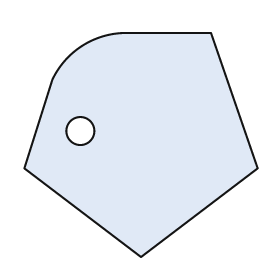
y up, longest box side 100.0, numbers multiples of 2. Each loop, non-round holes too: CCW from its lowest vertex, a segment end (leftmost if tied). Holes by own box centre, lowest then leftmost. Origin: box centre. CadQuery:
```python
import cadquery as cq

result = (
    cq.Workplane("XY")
    .moveTo(0.0, -48.0)
    .lineTo(50.0, -10.0)
    .lineTo(30.0, 48.0)
    .lineTo(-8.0, 48.0)
    .threePointArc((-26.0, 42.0), (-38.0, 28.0))
    .lineTo(-50.0, -10.0)
    .close()
    .moveTo(-26.0, 6.0)
    .circle(6.0)
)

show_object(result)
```